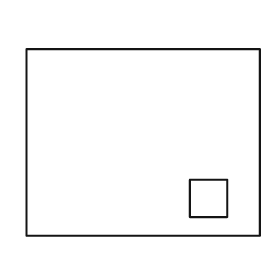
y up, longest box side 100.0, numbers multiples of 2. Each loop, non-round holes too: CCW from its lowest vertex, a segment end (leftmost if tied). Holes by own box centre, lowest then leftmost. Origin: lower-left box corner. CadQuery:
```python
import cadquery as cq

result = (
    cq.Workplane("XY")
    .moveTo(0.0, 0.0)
    .lineTo(100.0, 0.0)
    .lineTo(100.0, 80.0)
    .lineTo(0.0, 80.0)
    .close()
    .moveTo(70.0, 8.0)
    .lineTo(86.0, 8.0)
    .lineTo(86.0, 24.0)
    .lineTo(70.0, 24.0)
    .close()
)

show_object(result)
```